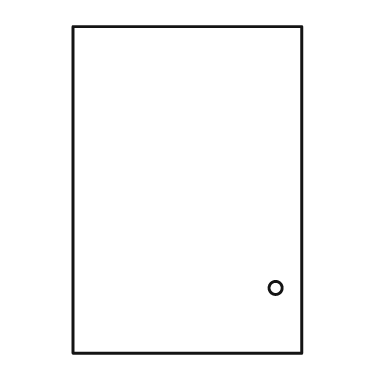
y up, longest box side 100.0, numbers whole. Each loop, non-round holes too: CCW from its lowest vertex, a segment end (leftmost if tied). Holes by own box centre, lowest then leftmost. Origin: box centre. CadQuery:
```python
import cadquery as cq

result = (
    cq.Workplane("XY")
    .moveTo(-35.0, -50.0)
    .lineTo(35.0, -50.0)
    .lineTo(35.0, 50.0)
    .lineTo(-35.0, 50.0)
    .close()
    .moveTo(27.0, -30.0)
    .circle(2.0)
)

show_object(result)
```